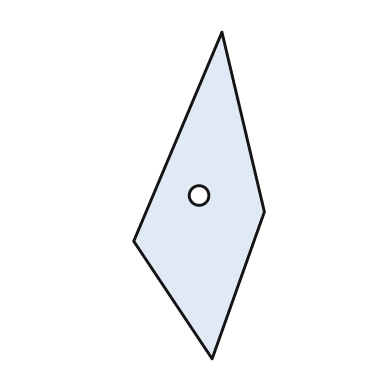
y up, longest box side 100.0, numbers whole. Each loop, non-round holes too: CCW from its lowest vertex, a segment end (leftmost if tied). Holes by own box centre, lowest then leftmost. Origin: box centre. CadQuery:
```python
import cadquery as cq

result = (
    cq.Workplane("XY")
    .moveTo(4.0, -50.0)
    .lineTo(20.0, -5.0)
    .lineTo(7.0, 50.0)
    .lineTo(-20.0, -14.0)
    .close()
    .moveTo(0.0, 0.0)
    .circle(3.0)
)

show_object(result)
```